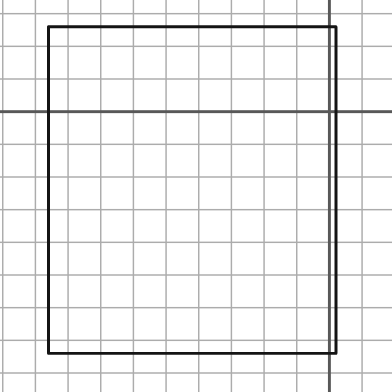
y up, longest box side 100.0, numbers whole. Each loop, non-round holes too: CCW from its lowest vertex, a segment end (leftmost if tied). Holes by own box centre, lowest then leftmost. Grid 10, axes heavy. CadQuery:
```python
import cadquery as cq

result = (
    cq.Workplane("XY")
    .moveTo(-86.0, -74.0)
    .lineTo(2.0, -74.0)
    .lineTo(2.0, 26.0)
    .lineTo(-86.0, 26.0)
    .close()
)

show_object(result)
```